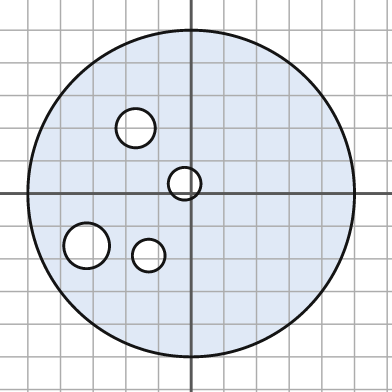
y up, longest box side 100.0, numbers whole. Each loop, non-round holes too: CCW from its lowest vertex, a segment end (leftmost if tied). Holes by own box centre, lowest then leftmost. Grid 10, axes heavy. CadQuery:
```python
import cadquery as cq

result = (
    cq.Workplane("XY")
    .moveTo(0.0, 0.0)
    .circle(50.0)
    .moveTo(-13.0, -19.0)
    .circle(5.0)
    .moveTo(-32.0, -16.0)
    .circle(7.0)
    .moveTo(-2.0, 3.0)
    .circle(5.0)
    .moveTo(-17.0, 20.0)
    .circle(6.0)
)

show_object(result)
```